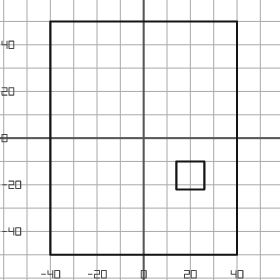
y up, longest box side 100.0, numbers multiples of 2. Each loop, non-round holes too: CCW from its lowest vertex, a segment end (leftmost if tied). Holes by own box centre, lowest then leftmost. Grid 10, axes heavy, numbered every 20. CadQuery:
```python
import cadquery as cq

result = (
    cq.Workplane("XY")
    .moveTo(-40.0, -50.0)
    .lineTo(40.0, -50.0)
    .lineTo(40.0, 50.0)
    .lineTo(-40.0, 50.0)
    .close()
    .moveTo(14.0, -22.0)
    .lineTo(26.0, -22.0)
    .lineTo(26.0, -10.0)
    .lineTo(14.0, -10.0)
    .close()
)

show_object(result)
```